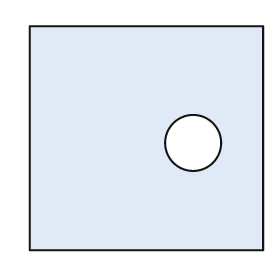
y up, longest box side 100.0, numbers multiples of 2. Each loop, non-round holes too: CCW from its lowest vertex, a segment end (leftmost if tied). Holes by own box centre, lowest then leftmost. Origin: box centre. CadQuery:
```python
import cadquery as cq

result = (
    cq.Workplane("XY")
    .moveTo(-50.0, -48.0)
    .lineTo(50.0, -48.0)
    .lineTo(50.0, 48.0)
    .lineTo(-50.0, 48.0)
    .close()
    .moveTo(20.0, -2.0)
    .circle(12.0)
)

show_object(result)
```